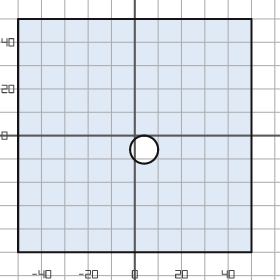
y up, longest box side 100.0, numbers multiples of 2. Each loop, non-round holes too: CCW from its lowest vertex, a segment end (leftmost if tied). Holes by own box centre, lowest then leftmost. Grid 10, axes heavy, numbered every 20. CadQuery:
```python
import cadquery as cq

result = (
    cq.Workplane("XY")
    .moveTo(-50.0, -50.0)
    .lineTo(50.0, -50.0)
    .lineTo(50.0, 50.0)
    .lineTo(-50.0, 50.0)
    .close()
    .moveTo(4.0, -6.0)
    .circle(6.0)
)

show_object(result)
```